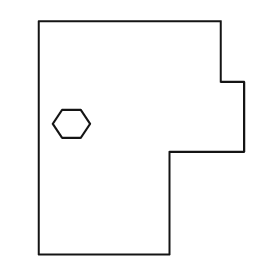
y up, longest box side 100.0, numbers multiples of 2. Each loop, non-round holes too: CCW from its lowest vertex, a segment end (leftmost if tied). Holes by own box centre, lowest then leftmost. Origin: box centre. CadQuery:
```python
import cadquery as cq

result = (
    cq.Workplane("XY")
    .moveTo(-44.0, -50.0)
    .lineTo(12.0, -50.0)
    .lineTo(12.0, -6.0)
    .lineTo(44.0, -6.0)
    .lineTo(44.0, 24.0)
    .lineTo(34.0, 24.0)
    .lineTo(34.0, 50.0)
    .lineTo(-44.0, 50.0)
    .close()
    .moveTo(-34.0, 0.0)
    .lineTo(-26.0, 0.0)
    .lineTo(-22.0, 6.0)
    .lineTo(-26.0, 12.0)
    .lineTo(-34.0, 12.0)
    .lineTo(-38.0, 6.0)
    .close()
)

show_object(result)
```